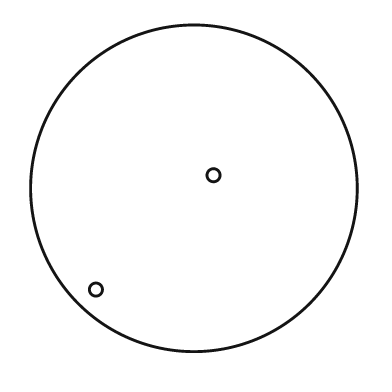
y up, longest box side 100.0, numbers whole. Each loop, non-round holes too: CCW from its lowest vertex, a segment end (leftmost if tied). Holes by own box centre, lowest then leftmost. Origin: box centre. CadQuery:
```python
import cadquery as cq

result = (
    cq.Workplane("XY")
    .moveTo(0.0, 0.0)
    .circle(50.0)
    .moveTo(-30.0, -31.0)
    .circle(2.0)
    .moveTo(6.0, 4.0)
    .circle(2.0)
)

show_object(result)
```